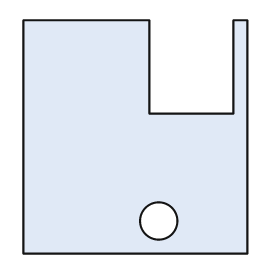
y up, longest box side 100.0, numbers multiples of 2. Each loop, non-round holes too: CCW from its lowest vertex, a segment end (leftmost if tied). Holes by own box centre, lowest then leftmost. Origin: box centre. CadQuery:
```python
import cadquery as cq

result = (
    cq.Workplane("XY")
    .moveTo(-48.0, -50.0)
    .lineTo(48.0, -50.0)
    .lineTo(48.0, 50.0)
    .lineTo(42.0, 50.0)
    .lineTo(42.0, 10.0)
    .lineTo(6.0, 10.0)
    .lineTo(6.0, 50.0)
    .lineTo(-48.0, 50.0)
    .close()
    .moveTo(10.0, -36.0)
    .circle(8.0)
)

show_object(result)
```